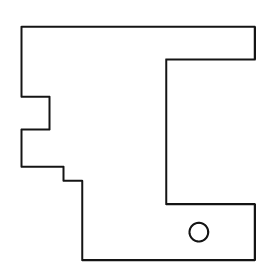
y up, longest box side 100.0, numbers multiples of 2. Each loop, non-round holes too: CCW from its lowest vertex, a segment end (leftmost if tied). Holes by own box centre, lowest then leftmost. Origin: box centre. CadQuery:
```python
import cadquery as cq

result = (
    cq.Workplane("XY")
    .moveTo(-24.0, -50.0)
    .lineTo(50.0, -50.0)
    .lineTo(50.0, -26.0)
    .lineTo(12.0, -26.0)
    .lineTo(12.0, 36.0)
    .lineTo(50.0, 36.0)
    .lineTo(50.0, 50.0)
    .lineTo(-50.0, 50.0)
    .lineTo(-50.0, 20.0)
    .lineTo(-38.0, 20.0)
    .lineTo(-38.0, 6.0)
    .lineTo(-50.0, 6.0)
    .lineTo(-50.0, -10.0)
    .lineTo(-32.0, -10.0)
    .lineTo(-32.0, -16.0)
    .lineTo(-24.0, -16.0)
    .close()
    .moveTo(26.0, -38.0)
    .circle(4.0)
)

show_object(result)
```